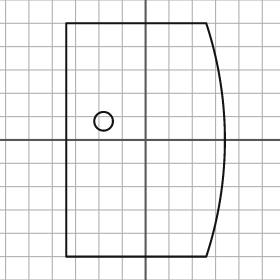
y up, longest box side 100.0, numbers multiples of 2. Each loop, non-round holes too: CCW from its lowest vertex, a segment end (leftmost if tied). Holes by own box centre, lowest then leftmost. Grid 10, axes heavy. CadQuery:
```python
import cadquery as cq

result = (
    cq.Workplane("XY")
    .moveTo(-34.0, -50.0)
    .lineTo(26.0, -50.0)
    .threePointArc((34.0, 0.0), (26.0, 50.0))
    .lineTo(-34.0, 50.0)
    .close()
    .moveTo(-18.0, 8.0)
    .circle(4.0)
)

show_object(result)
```